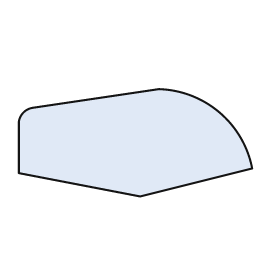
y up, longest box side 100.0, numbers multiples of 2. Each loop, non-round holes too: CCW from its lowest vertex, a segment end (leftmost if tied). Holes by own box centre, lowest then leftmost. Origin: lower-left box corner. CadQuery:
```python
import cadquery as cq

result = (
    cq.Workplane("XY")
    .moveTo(52.0, 0.0)
    .lineTo(100.0, 12.0)
    .threePointArc((86.0, 36.0), (60.0, 46.0))
    .lineTo(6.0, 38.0)
    .threePointArc((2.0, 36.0), (0.0, 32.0))
    .lineTo(0.0, 10.0)
    .close()
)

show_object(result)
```